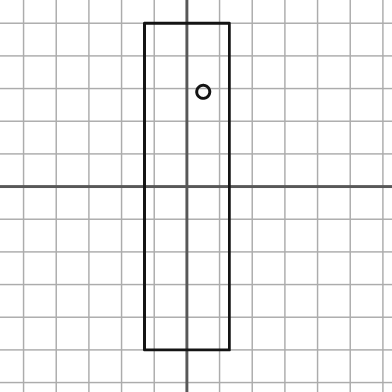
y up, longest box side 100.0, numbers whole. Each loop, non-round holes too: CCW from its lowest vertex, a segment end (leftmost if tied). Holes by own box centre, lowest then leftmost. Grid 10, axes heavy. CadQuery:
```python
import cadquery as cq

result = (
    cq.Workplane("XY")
    .moveTo(-13.0, -50.0)
    .lineTo(13.0, -50.0)
    .lineTo(13.0, 50.0)
    .lineTo(-13.0, 50.0)
    .close()
    .moveTo(5.0, 29.0)
    .circle(2.0)
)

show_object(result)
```